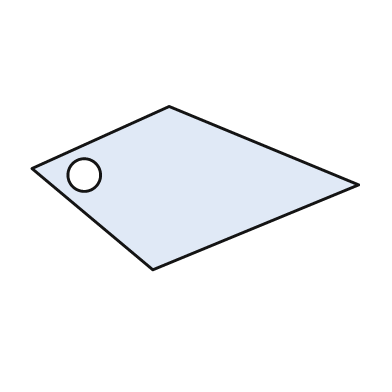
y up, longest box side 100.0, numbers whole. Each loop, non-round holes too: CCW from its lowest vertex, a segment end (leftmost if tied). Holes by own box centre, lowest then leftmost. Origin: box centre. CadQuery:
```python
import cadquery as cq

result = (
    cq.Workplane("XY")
    .moveTo(-13.0, -25.0)
    .lineTo(50.0, 1.0)
    .lineTo(-8.0, 25.0)
    .lineTo(-50.0, 6.0)
    .close()
    .moveTo(-34.0, 4.0)
    .circle(5.0)
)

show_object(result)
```